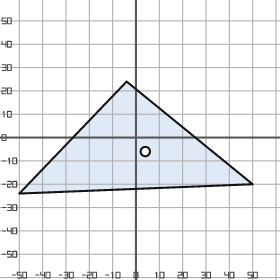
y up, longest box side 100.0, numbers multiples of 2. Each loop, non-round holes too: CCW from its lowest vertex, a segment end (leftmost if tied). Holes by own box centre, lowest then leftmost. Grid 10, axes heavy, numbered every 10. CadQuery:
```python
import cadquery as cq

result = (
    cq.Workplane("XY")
    .moveTo(-50.0, -24.0)
    .lineTo(50.0, -20.0)
    .lineTo(-4.0, 24.0)
    .close()
    .moveTo(4.0, -6.0)
    .circle(2.0)
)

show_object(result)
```